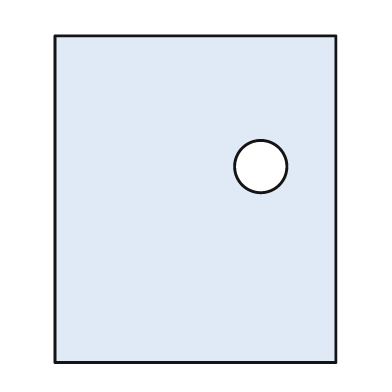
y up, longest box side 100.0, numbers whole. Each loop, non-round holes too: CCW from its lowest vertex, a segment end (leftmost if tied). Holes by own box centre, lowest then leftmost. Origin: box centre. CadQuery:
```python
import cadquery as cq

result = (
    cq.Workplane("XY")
    .moveTo(-43.0, -50.0)
    .lineTo(43.0, -50.0)
    .lineTo(43.0, 50.0)
    .lineTo(-43.0, 50.0)
    .close()
    .moveTo(20.0, 10.0)
    .circle(8.0)
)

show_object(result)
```